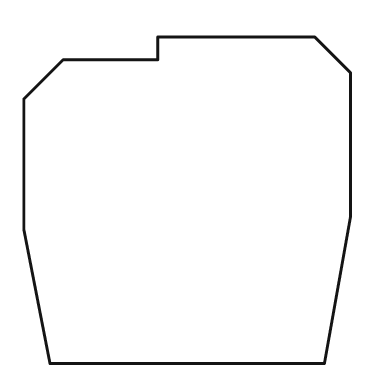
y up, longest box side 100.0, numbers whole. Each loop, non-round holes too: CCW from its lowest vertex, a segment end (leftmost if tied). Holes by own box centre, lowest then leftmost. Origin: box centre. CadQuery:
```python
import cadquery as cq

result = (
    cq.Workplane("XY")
    .moveTo(-42.0, -50.0)
    .lineTo(42.0, -50.0)
    .lineTo(50.0, -5.0)
    .lineTo(50.0, 39.0)
    .lineTo(39.0, 50.0)
    .lineTo(-9.0, 50.0)
    .lineTo(-9.0, 43.0)
    .lineTo(-38.0, 43.0)
    .lineTo(-50.0, 31.0)
    .lineTo(-50.0, -9.0)
    .close()
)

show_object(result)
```